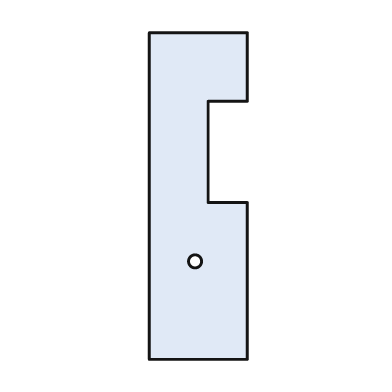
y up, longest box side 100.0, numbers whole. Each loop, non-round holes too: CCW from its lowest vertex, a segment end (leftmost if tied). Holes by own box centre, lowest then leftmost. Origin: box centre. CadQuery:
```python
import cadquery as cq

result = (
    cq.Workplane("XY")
    .moveTo(-15.0, -50.0)
    .lineTo(15.0, -50.0)
    .lineTo(15.0, -2.0)
    .lineTo(3.0, -2.0)
    .lineTo(3.0, 29.0)
    .lineTo(15.0, 29.0)
    .lineTo(15.0, 50.0)
    .lineTo(-15.0, 50.0)
    .close()
    .moveTo(-1.0, -20.0)
    .circle(2.0)
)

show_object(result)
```